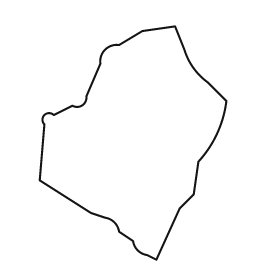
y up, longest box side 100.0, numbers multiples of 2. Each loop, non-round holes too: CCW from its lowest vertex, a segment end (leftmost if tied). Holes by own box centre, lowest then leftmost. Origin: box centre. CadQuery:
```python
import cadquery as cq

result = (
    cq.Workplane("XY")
    .moveTo(10.0, -50.0)
    .lineTo(20.0, -28.0)
    .lineTo(26.0, -22.0)
    .lineTo(28.0, -8.0)
    .threePointArc((36.0, 4.0), (40.0, 18.0))
    .lineTo(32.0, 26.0)
    .threePointArc((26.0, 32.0), (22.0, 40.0))
    .lineTo(18.0, 50.0)
    .lineTo(4.0, 48.0)
    .lineTo(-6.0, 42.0)
    .threePointArc((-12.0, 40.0), (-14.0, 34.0))
    .lineTo(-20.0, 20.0)
    .threePointArc((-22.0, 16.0), (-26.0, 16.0))
    .lineTo(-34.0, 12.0)
    .threePointArc((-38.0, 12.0), (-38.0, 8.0))
    .lineTo(-40.0, -16.0)
    .lineTo(-18.0, -30.0)
    .lineTo(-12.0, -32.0)
    .threePointArc((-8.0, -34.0), (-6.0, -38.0))
    .lineTo(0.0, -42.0)
    .threePointArc((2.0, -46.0), (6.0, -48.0))
    .close()
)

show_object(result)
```